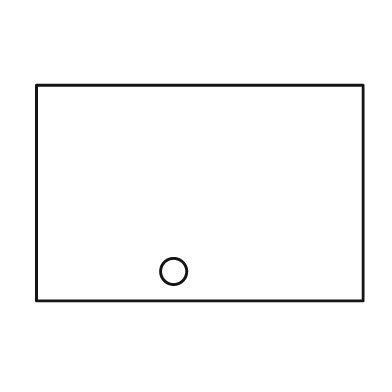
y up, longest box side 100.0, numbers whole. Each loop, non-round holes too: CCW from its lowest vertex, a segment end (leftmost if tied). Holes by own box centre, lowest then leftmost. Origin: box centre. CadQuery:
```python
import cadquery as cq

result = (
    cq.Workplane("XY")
    .moveTo(-50.0, -33.0)
    .lineTo(50.0, -33.0)
    .lineTo(50.0, 33.0)
    .lineTo(-50.0, 33.0)
    .close()
    .moveTo(-8.0, -24.0)
    .circle(4.0)
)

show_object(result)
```